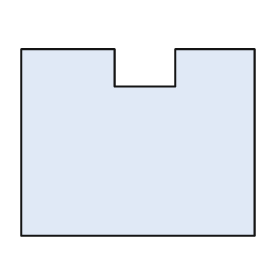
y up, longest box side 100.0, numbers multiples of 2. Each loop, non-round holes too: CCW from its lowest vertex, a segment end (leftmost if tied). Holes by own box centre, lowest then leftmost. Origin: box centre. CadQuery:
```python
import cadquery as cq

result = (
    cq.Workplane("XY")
    .moveTo(-50.0, -40.0)
    .lineTo(50.0, -40.0)
    .lineTo(50.0, 40.0)
    .lineTo(16.0, 40.0)
    .lineTo(16.0, 24.0)
    .lineTo(-10.0, 24.0)
    .lineTo(-10.0, 40.0)
    .lineTo(-50.0, 40.0)
    .close()
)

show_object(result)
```